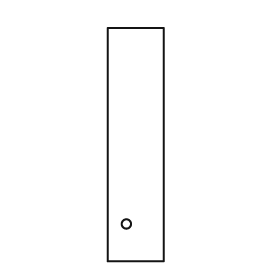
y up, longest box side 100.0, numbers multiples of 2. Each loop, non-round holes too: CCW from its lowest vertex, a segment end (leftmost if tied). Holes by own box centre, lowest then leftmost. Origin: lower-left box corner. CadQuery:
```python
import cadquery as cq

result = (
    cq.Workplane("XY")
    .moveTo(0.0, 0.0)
    .lineTo(24.0, 0.0)
    .lineTo(24.0, 100.0)
    .lineTo(0.0, 100.0)
    .close()
    .moveTo(8.0, 16.0)
    .circle(2.0)
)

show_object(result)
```